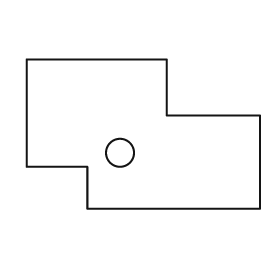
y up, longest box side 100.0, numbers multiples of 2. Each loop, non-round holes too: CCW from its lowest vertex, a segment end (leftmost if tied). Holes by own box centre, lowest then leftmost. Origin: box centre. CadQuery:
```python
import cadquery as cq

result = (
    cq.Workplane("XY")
    .moveTo(-24.0, -32.0)
    .lineTo(50.0, -32.0)
    .lineTo(50.0, 8.0)
    .lineTo(10.0, 8.0)
    .lineTo(10.0, 32.0)
    .lineTo(-50.0, 32.0)
    .lineTo(-50.0, -14.0)
    .lineTo(-24.0, -14.0)
    .close()
    .moveTo(-10.0, -8.0)
    .circle(6.0)
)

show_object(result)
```